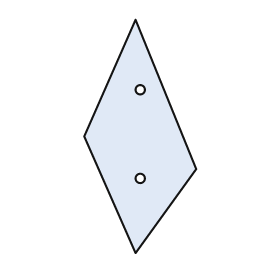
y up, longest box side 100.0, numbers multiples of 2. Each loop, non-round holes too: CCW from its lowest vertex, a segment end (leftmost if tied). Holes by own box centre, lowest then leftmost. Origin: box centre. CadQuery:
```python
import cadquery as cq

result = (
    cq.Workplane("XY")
    .moveTo(-2.0, -50.0)
    .lineTo(24.0, -14.0)
    .lineTo(-2.0, 50.0)
    .lineTo(-24.0, 0.0)
    .close()
    .moveTo(0.0, -18.0)
    .circle(2.0)
    .moveTo(0.0, 20.0)
    .circle(2.0)
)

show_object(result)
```